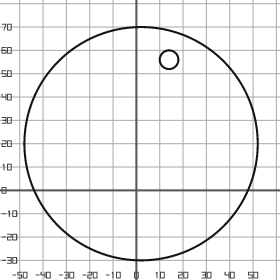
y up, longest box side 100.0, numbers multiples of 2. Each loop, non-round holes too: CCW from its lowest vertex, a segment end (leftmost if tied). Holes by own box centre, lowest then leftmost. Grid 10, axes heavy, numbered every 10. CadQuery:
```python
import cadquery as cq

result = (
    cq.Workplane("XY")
    .moveTo(2.0, 20.0)
    .circle(50.0)
    .moveTo(14.0, 56.0)
    .circle(4.0)
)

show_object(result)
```